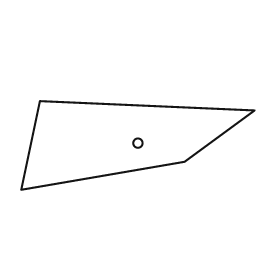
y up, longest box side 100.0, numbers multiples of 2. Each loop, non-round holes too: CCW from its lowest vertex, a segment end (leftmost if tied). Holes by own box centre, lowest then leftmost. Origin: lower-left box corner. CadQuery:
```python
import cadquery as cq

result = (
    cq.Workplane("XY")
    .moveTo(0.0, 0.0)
    .lineTo(70.0, 12.0)
    .lineTo(100.0, 34.0)
    .lineTo(8.0, 38.0)
    .close()
    .moveTo(50.0, 20.0)
    .circle(2.0)
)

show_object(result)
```